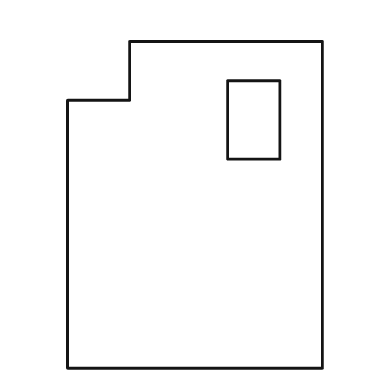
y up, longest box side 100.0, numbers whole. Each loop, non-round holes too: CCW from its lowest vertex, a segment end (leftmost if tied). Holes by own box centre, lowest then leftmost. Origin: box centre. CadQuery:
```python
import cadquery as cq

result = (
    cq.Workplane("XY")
    .moveTo(-39.0, -50.0)
    .lineTo(39.0, -50.0)
    .lineTo(39.0, 50.0)
    .lineTo(-20.0, 50.0)
    .lineTo(-20.0, 32.0)
    .lineTo(-39.0, 32.0)
    .close()
    .moveTo(10.0, 14.0)
    .lineTo(26.0, 14.0)
    .lineTo(26.0, 38.0)
    .lineTo(10.0, 38.0)
    .close()
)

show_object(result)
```